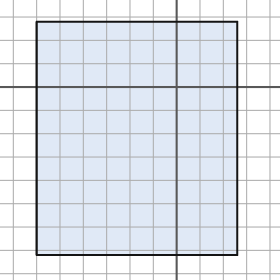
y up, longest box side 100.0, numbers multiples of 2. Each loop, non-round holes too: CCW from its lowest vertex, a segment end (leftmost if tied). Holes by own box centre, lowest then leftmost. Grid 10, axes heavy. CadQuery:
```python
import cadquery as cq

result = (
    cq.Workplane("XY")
    .moveTo(-60.0, -72.0)
    .lineTo(26.0, -72.0)
    .lineTo(26.0, 28.0)
    .lineTo(-60.0, 28.0)
    .close()
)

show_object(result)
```